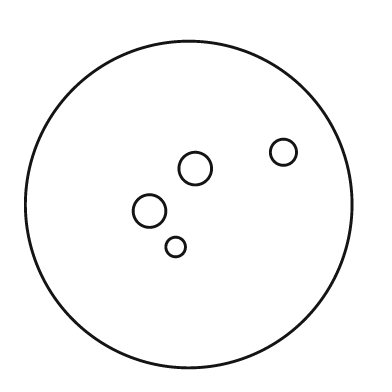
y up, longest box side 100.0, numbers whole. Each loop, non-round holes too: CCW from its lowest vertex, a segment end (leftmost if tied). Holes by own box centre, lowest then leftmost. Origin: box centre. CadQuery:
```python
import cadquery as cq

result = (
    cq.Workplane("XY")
    .moveTo(0.0, 0.0)
    .circle(50.0)
    .moveTo(-4.0, -13.0)
    .circle(3.0)
    .moveTo(-12.0, -2.0)
    .circle(5.0)
    .moveTo(2.0, 11.0)
    .circle(5.0)
    .moveTo(29.0, 16.0)
    .circle(4.0)
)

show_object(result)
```